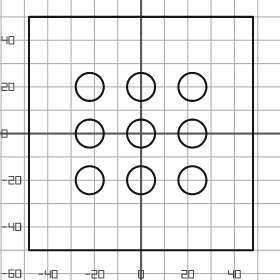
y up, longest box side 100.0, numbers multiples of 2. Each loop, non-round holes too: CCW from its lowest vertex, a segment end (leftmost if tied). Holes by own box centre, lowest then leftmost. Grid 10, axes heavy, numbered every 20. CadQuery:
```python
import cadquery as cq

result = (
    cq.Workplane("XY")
    .moveTo(-48.0, -50.0)
    .lineTo(48.0, -50.0)
    .lineTo(48.0, 50.0)
    .lineTo(-48.0, 50.0)
    .close()
    .moveTo(-22.0, -20.0)
    .circle(6.0)
    .moveTo(0.0, -20.0)
    .circle(6.0)
    .moveTo(22.0, -20.0)
    .circle(6.0)
    .moveTo(-22.0, 0.0)
    .circle(6.0)
    .moveTo(0.0, 0.0)
    .circle(6.0)
    .moveTo(22.0, 0.0)
    .circle(6.0)
    .moveTo(-22.0, 20.0)
    .circle(6.0)
    .moveTo(0.0, 20.0)
    .circle(6.0)
    .moveTo(22.0, 20.0)
    .circle(6.0)
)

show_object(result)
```